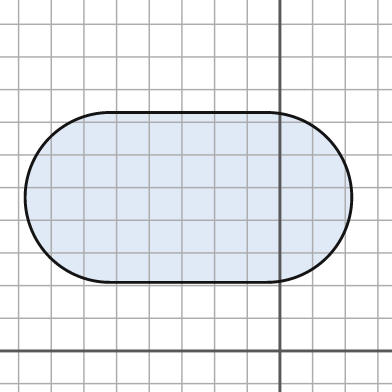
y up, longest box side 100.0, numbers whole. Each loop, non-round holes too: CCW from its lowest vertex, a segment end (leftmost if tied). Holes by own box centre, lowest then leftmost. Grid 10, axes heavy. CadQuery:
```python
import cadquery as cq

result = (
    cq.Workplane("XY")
    .moveTo(-52.0, 21.0)
    .lineTo(-4.0, 21.0)
    .threePointArc((22.0, 47.0), (-4.0, 73.0))
    .lineTo(-52.0, 73.0)
    .threePointArc((-78.0, 47.0), (-52.0, 21.0))
    .close()
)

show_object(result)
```